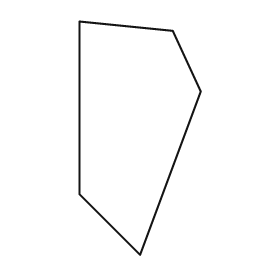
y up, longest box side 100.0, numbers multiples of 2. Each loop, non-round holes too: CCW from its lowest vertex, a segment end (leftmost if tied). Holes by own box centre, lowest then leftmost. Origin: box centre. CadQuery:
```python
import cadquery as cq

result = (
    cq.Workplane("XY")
    .moveTo(0.0, -50.0)
    .lineTo(26.0, 20.0)
    .lineTo(14.0, 46.0)
    .lineTo(-26.0, 50.0)
    .lineTo(-26.0, -24.0)
    .close()
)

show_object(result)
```